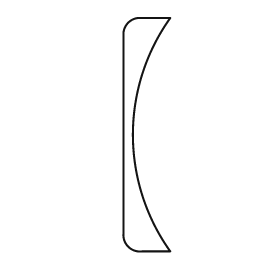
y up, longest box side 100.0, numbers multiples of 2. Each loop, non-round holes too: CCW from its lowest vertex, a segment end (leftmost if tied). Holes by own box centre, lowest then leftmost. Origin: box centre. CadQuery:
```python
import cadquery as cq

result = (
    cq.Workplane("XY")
    .moveTo(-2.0, -50.0)
    .lineTo(10.0, -50.0)
    .threePointArc((-6.0, 0.0), (10.0, 50.0))
    .lineTo(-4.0, 50.0)
    .threePointArc((-8.0, 48.0), (-10.0, 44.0))
    .lineTo(-10.0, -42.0)
    .threePointArc((-8.0, -48.0), (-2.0, -50.0))
    .close()
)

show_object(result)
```